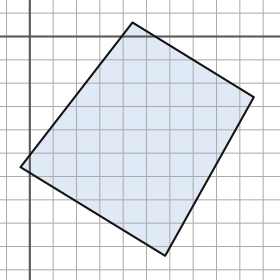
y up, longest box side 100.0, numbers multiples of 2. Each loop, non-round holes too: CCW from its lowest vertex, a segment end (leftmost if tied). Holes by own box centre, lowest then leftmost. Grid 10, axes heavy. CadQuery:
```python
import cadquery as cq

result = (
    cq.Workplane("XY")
    .moveTo(58.0, -94.0)
    .lineTo(96.0, -26.0)
    .lineTo(44.0, 6.0)
    .lineTo(-4.0, -56.0)
    .close()
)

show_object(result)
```